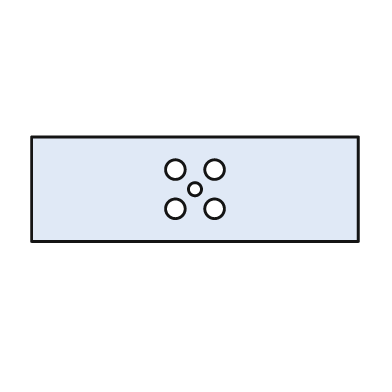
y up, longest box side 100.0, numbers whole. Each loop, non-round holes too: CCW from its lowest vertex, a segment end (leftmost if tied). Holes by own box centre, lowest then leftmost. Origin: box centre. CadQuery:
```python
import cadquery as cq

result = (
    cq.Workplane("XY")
    .moveTo(-50.0, -16.0)
    .lineTo(50.0, -16.0)
    .lineTo(50.0, 16.0)
    .lineTo(-50.0, 16.0)
    .close()
    .moveTo(-6.0, -6.0)
    .circle(3.0)
    .moveTo(6.0, -6.0)
    .circle(3.0)
    .moveTo(0.0, 0.0)
    .circle(2.0)
    .moveTo(-6.0, 6.0)
    .circle(3.0)
    .moveTo(6.0, 6.0)
    .circle(3.0)
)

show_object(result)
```